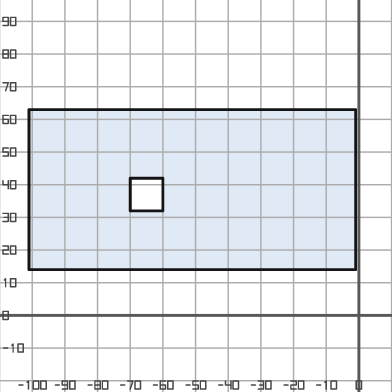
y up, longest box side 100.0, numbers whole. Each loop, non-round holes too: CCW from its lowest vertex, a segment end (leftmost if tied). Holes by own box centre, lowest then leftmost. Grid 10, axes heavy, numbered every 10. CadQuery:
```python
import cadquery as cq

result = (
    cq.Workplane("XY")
    .moveTo(-101.0, 14.0)
    .lineTo(-1.0, 14.0)
    .lineTo(-1.0, 63.0)
    .lineTo(-101.0, 63.0)
    .close()
    .moveTo(-70.0, 32.0)
    .lineTo(-60.0, 32.0)
    .lineTo(-60.0, 42.0)
    .lineTo(-70.0, 42.0)
    .close()
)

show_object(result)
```